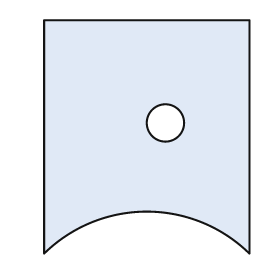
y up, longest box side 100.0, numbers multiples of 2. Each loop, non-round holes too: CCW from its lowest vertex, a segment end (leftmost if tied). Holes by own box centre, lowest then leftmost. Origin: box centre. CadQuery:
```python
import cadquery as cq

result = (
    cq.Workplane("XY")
    .moveTo(-44.0, -50.0)
    .threePointArc((0.0, -32.0), (44.0, -50.0))
    .lineTo(44.0, 50.0)
    .lineTo(-44.0, 50.0)
    .close()
    .moveTo(8.0, 6.0)
    .circle(8.0)
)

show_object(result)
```